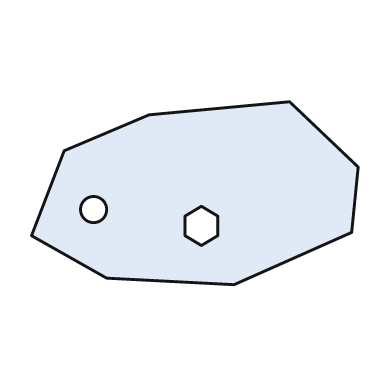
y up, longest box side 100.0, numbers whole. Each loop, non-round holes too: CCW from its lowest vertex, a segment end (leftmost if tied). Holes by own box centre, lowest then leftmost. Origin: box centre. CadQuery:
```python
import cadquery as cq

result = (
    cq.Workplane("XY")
    .moveTo(12.0, -28.0)
    .lineTo(48.0, -12.0)
    .lineTo(50.0, 8.0)
    .lineTo(29.0, 28.0)
    .lineTo(-14.0, 24.0)
    .lineTo(-40.0, 13.0)
    .lineTo(-50.0, -13.0)
    .lineTo(-27.0, -26.0)
    .close()
    .moveTo(2.0, -16.0)
    .lineTo(7.0, -13.0)
    .lineTo(7.0, -7.0)
    .lineTo(2.0, -4.0)
    .lineTo(-3.0, -7.0)
    .lineTo(-3.0, -13.0)
    .close()
    .moveTo(-31.0, -5.0)
    .circle(4.0)
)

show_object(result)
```